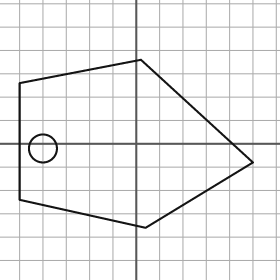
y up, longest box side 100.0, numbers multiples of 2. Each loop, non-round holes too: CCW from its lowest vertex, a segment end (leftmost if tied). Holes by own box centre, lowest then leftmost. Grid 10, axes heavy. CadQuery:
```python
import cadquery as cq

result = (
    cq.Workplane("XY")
    .moveTo(4.0, -36.0)
    .lineTo(50.0, -8.0)
    .lineTo(2.0, 36.0)
    .lineTo(-50.0, 26.0)
    .lineTo(-50.0, -24.0)
    .close()
    .moveTo(-40.0, -2.0)
    .circle(6.0)
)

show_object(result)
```